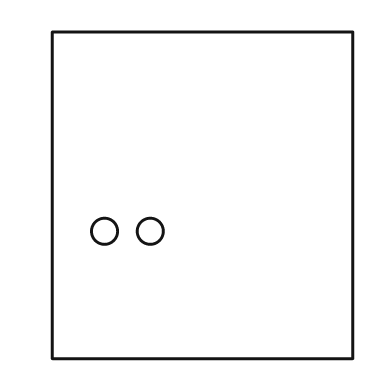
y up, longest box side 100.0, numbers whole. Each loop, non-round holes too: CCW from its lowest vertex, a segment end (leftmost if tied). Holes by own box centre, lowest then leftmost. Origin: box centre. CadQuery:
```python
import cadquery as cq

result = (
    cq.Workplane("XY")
    .moveTo(-46.0, -50.0)
    .lineTo(46.0, -50.0)
    .lineTo(46.0, 50.0)
    .lineTo(-46.0, 50.0)
    .close()
    .moveTo(-30.0, -11.0)
    .circle(4.0)
    .moveTo(-16.0, -11.0)
    .circle(4.0)
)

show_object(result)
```